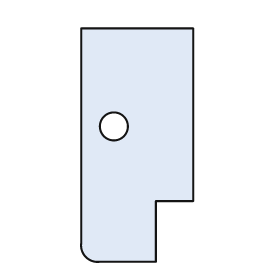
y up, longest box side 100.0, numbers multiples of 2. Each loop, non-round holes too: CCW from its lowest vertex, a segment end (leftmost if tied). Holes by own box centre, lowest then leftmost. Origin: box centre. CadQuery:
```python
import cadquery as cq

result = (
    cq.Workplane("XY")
    .moveTo(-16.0, -50.0)
    .lineTo(8.0, -50.0)
    .lineTo(8.0, -24.0)
    .lineTo(24.0, -24.0)
    .lineTo(24.0, 50.0)
    .lineTo(-24.0, 50.0)
    .lineTo(-24.0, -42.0)
    .threePointArc((-22.0, -48.0), (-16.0, -50.0))
    .close()
    .moveTo(-10.0, 8.0)
    .circle(6.0)
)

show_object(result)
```